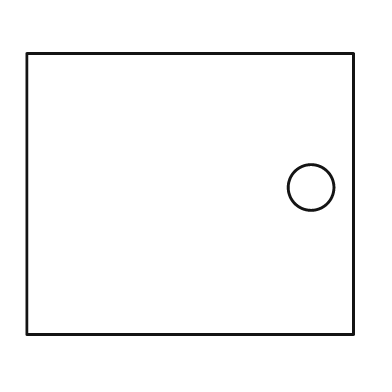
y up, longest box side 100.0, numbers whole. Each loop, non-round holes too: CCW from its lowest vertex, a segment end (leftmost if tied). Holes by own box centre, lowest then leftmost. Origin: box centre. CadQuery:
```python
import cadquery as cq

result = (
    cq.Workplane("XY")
    .moveTo(-50.0, -43.0)
    .lineTo(50.0, -43.0)
    .lineTo(50.0, 43.0)
    .lineTo(-50.0, 43.0)
    .close()
    .moveTo(37.0, 2.0)
    .circle(7.0)
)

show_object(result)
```